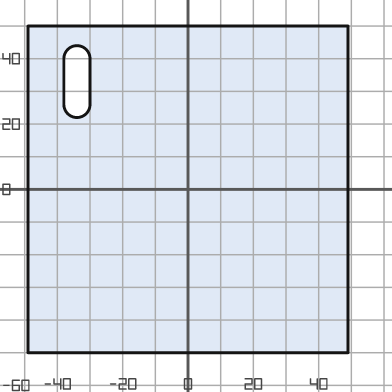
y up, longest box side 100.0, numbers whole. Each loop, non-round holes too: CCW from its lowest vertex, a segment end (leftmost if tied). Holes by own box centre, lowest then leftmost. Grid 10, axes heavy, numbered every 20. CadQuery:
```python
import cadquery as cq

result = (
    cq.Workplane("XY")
    .moveTo(-49.0, -50.0)
    .lineTo(49.0, -50.0)
    .lineTo(49.0, 50.0)
    .lineTo(-49.0, 50.0)
    .close()
    .moveTo(-38.0, 26.0)
    .threePointArc((-34.0, 22.0), (-30.0, 26.0))
    .lineTo(-30.0, 40.0)
    .threePointArc((-34.0, 44.0), (-38.0, 40.0))
    .close()
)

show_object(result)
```